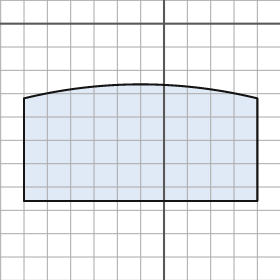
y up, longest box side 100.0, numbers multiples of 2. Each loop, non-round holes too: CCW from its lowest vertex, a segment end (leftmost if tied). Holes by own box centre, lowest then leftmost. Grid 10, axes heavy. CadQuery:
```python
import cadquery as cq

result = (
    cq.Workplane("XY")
    .moveTo(-60.0, -76.0)
    .lineTo(40.0, -76.0)
    .lineTo(40.0, -32.0)
    .threePointArc((-10.0, -26.0), (-60.0, -32.0))
    .close()
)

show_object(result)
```